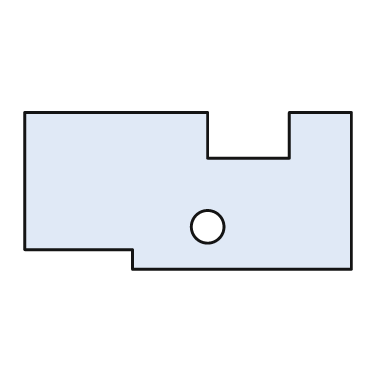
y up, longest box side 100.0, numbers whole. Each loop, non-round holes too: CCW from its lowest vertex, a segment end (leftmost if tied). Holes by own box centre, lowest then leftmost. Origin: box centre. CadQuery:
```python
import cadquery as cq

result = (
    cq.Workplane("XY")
    .moveTo(-17.0, -24.0)
    .lineTo(50.0, -24.0)
    .lineTo(50.0, 24.0)
    .lineTo(31.0, 24.0)
    .lineTo(31.0, 10.0)
    .lineTo(6.0, 10.0)
    .lineTo(6.0, 24.0)
    .lineTo(-50.0, 24.0)
    .lineTo(-50.0, -18.0)
    .lineTo(-17.0, -18.0)
    .close()
    .moveTo(6.0, -11.0)
    .circle(5.0)
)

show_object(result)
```